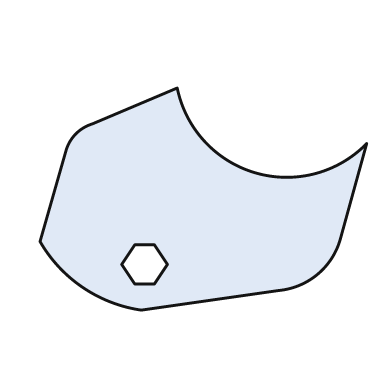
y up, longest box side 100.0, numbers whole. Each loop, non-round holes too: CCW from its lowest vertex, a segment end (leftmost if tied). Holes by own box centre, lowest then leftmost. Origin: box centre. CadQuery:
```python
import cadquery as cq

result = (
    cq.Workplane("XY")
    .moveTo(-19.0, -34.0)
    .lineTo(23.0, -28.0)
    .threePointArc((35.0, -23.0), (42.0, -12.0))
    .lineTo(50.0, 17.0)
    .threePointArc((16.0, 8.0), (-8.0, 34.0))
    .lineTo(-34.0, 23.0)
    .threePointArc((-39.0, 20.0), (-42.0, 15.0))
    .lineTo(-50.0, -13.0)
    .threePointArc((-37.0, -27.0), (-19.0, -34.0))
    .close()
    .moveTo(-21.0, -26.0)
    .lineTo(-15.0, -26.0)
    .lineTo(-11.0, -20.0)
    .lineTo(-15.0, -14.0)
    .lineTo(-21.0, -14.0)
    .lineTo(-25.0, -20.0)
    .close()
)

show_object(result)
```